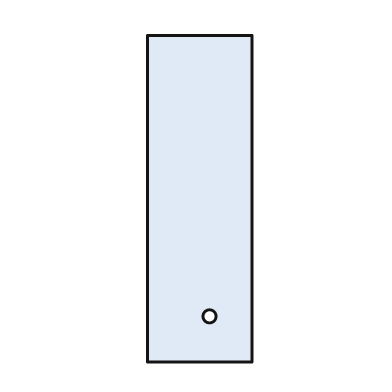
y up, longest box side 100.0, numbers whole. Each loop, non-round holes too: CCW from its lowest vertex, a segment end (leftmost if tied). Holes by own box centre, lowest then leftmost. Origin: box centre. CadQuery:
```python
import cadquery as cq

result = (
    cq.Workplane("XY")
    .moveTo(-16.0, -50.0)
    .lineTo(16.0, -50.0)
    .lineTo(16.0, 50.0)
    .lineTo(-16.0, 50.0)
    .close()
    .moveTo(3.0, -36.0)
    .circle(2.0)
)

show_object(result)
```